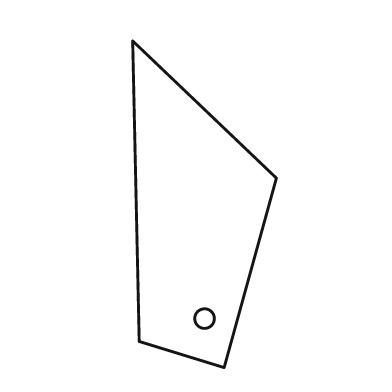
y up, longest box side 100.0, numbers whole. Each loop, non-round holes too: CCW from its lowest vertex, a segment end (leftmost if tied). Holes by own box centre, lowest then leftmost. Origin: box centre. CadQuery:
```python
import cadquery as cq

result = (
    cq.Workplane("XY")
    .moveTo(6.0, -50.0)
    .lineTo(22.0, 8.0)
    .lineTo(-22.0, 50.0)
    .lineTo(-20.0, -42.0)
    .close()
    .moveTo(0.0, -35.0)
    .circle(3.0)
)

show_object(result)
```